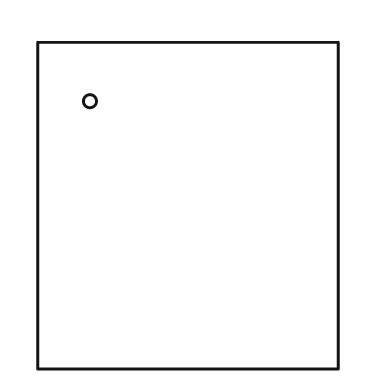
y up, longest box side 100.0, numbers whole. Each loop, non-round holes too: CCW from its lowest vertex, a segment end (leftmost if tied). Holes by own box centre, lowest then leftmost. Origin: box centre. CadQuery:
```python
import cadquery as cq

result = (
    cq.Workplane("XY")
    .moveTo(-46.0, -50.0)
    .lineTo(46.0, -50.0)
    .lineTo(46.0, 50.0)
    .lineTo(-46.0, 50.0)
    .close()
    .moveTo(-30.0, 32.0)
    .circle(2.0)
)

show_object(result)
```